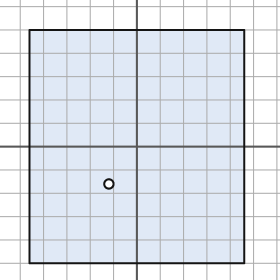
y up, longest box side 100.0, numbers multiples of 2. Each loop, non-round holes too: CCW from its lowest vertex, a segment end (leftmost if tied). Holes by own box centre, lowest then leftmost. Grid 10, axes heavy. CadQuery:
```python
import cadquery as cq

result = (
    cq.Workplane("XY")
    .moveTo(-46.0, -50.0)
    .lineTo(46.0, -50.0)
    .lineTo(46.0, 50.0)
    .lineTo(-46.0, 50.0)
    .close()
    .moveTo(-12.0, -16.0)
    .circle(2.0)
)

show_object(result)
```